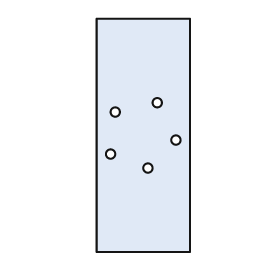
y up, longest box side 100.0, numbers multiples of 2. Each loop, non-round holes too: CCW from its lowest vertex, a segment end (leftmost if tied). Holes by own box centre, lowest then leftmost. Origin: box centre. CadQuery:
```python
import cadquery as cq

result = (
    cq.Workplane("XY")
    .moveTo(-20.0, -50.0)
    .lineTo(20.0, -50.0)
    .lineTo(20.0, 50.0)
    .lineTo(-20.0, 50.0)
    .close()
    .moveTo(2.0, -14.0)
    .circle(2.0)
    .moveTo(-14.0, -8.0)
    .circle(2.0)
    .moveTo(14.0, -2.0)
    .circle(2.0)
    .moveTo(-12.0, 10.0)
    .circle(2.0)
    .moveTo(6.0, 14.0)
    .circle(2.0)
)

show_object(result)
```